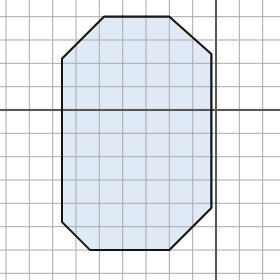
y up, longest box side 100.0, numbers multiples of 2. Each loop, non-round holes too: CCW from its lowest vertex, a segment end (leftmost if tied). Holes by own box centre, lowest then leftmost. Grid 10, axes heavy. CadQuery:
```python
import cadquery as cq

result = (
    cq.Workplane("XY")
    .moveTo(-54.0, -60.0)
    .lineTo(-20.0, -60.0)
    .lineTo(-2.0, -42.0)
    .lineTo(-2.0, 24.0)
    .lineTo(-20.0, 40.0)
    .lineTo(-48.0, 40.0)
    .lineTo(-66.0, 22.0)
    .lineTo(-66.0, -48.0)
    .close()
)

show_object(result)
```